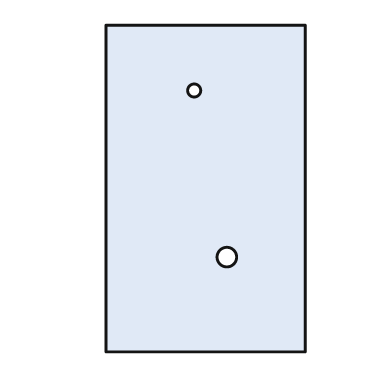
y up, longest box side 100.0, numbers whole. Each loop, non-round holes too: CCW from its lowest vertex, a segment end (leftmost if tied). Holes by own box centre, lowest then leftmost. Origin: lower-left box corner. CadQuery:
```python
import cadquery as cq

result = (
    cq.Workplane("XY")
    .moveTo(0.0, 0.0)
    .lineTo(61.0, 0.0)
    .lineTo(61.0, 100.0)
    .lineTo(0.0, 100.0)
    .close()
    .moveTo(37.0, 29.0)
    .circle(3.0)
    .moveTo(27.0, 80.0)
    .circle(2.0)
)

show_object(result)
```